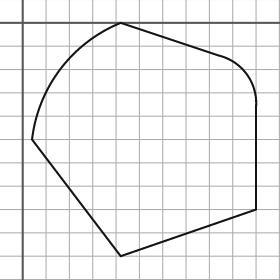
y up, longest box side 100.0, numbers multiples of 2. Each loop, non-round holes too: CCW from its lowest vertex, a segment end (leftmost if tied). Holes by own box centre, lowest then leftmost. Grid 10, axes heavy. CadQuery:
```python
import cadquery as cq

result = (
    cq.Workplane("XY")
    .moveTo(42.0, -100.0)
    .lineTo(100.0, -80.0)
    .lineTo(100.0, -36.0)
    .threePointArc((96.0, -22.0), (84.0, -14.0))
    .lineTo(42.0, 0.0)
    .threePointArc((16.0, -20.0), (4.0, -50.0))
    .close()
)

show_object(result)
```